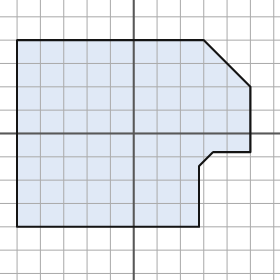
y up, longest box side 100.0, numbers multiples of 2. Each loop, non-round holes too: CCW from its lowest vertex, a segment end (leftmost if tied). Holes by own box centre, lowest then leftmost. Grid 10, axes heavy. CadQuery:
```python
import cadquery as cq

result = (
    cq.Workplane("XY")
    .moveTo(-50.0, -40.0)
    .lineTo(28.0, -40.0)
    .lineTo(28.0, -14.0)
    .lineTo(34.0, -8.0)
    .lineTo(50.0, -8.0)
    .lineTo(50.0, 20.0)
    .lineTo(30.0, 40.0)
    .lineTo(-50.0, 40.0)
    .close()
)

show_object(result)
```